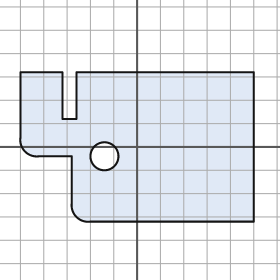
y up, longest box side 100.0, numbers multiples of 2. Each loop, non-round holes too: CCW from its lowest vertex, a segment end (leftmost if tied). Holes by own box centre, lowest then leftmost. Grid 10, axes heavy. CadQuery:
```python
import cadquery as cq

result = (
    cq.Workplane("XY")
    .moveTo(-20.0, -32.0)
    .lineTo(50.0, -32.0)
    .lineTo(50.0, 32.0)
    .lineTo(-26.0, 32.0)
    .lineTo(-26.0, 12.0)
    .lineTo(-32.0, 12.0)
    .lineTo(-32.0, 32.0)
    .lineTo(-50.0, 32.0)
    .lineTo(-50.0, 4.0)
    .threePointArc((-48.0, -2.0), (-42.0, -4.0))
    .lineTo(-28.0, -4.0)
    .lineTo(-28.0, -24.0)
    .threePointArc((-26.0, -30.0), (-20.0, -32.0))
    .close()
    .moveTo(-14.0, -4.0)
    .circle(6.0)
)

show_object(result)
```